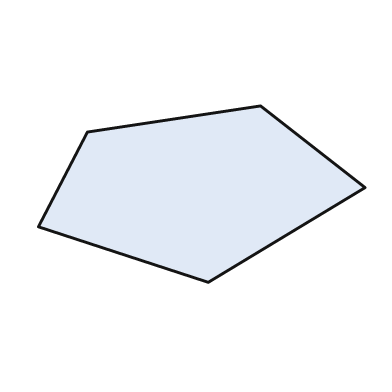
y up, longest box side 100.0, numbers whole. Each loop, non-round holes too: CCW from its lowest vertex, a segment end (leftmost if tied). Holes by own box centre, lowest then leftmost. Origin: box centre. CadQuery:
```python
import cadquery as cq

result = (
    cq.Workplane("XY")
    .moveTo(2.0, -27.0)
    .lineTo(50.0, 2.0)
    .lineTo(18.0, 27.0)
    .lineTo(-35.0, 19.0)
    .lineTo(-50.0, -10.0)
    .close()
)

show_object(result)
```